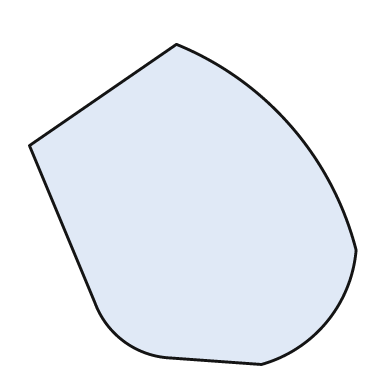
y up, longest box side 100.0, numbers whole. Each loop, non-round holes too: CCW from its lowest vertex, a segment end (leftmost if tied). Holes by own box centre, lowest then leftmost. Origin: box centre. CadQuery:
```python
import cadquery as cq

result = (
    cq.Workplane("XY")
    .moveTo(21.0, -49.0)
    .threePointArc((41.0, -36.0), (50.0, -14.0))
    .threePointArc((30.0, 24.0), (-5.0, 49.0))
    .lineTo(-50.0, 18.0)
    .lineTo(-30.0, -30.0)
    .threePointArc((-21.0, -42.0), (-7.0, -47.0))
    .close()
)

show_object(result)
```